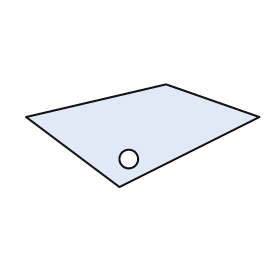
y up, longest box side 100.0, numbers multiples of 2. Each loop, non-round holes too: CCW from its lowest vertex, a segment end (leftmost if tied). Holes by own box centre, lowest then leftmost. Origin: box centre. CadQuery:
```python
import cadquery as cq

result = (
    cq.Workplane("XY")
    .moveTo(-10.0, -22.0)
    .lineTo(50.0, 8.0)
    .lineTo(10.0, 22.0)
    .lineTo(-50.0, 8.0)
    .close()
    .moveTo(-6.0, -10.0)
    .circle(4.0)
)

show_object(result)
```